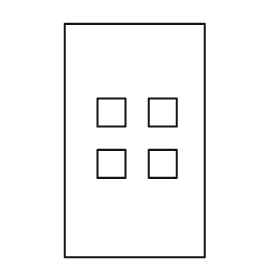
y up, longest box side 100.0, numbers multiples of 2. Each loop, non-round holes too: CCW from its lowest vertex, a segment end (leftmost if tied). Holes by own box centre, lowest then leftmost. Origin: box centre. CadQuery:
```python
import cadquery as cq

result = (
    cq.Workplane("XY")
    .moveTo(-30.0, -50.0)
    .lineTo(30.0, -50.0)
    .lineTo(30.0, 50.0)
    .lineTo(-30.0, 50.0)
    .close()
    .moveTo(-16.0, -16.0)
    .lineTo(-4.0, -16.0)
    .lineTo(-4.0, -4.0)
    .lineTo(-16.0, -4.0)
    .close()
    .moveTo(6.0, -16.0)
    .lineTo(18.0, -16.0)
    .lineTo(18.0, -4.0)
    .lineTo(6.0, -4.0)
    .close()
    .moveTo(-16.0, 6.0)
    .lineTo(-4.0, 6.0)
    .lineTo(-4.0, 18.0)
    .lineTo(-16.0, 18.0)
    .close()
    .moveTo(6.0, 6.0)
    .lineTo(18.0, 6.0)
    .lineTo(18.0, 18.0)
    .lineTo(6.0, 18.0)
    .close()
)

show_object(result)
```